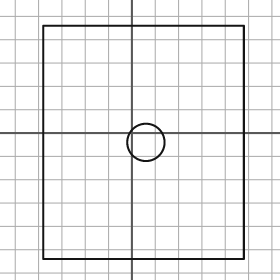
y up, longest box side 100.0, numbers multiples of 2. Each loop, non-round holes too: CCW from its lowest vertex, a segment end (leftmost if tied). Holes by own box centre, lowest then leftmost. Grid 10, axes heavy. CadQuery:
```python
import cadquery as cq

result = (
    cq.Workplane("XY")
    .moveTo(-38.0, -54.0)
    .lineTo(48.0, -54.0)
    .lineTo(48.0, 46.0)
    .lineTo(-38.0, 46.0)
    .close()
    .moveTo(6.0, -4.0)
    .circle(8.0)
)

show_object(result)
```